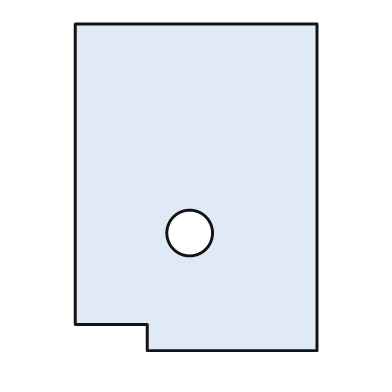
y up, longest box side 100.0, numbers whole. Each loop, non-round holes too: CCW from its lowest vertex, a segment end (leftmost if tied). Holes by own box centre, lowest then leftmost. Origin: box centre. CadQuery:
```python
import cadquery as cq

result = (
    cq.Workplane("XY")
    .moveTo(-15.0, -50.0)
    .lineTo(37.0, -50.0)
    .lineTo(37.0, 50.0)
    .lineTo(-37.0, 50.0)
    .lineTo(-37.0, -42.0)
    .lineTo(-15.0, -42.0)
    .close()
    .moveTo(-2.0, -14.0)
    .circle(7.0)
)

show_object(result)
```